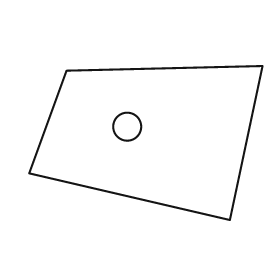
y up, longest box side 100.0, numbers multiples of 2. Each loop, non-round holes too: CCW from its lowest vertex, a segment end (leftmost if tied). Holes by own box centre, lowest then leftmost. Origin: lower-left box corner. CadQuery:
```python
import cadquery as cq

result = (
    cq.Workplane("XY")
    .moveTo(86.0, 0.0)
    .lineTo(100.0, 66.0)
    .lineTo(16.0, 64.0)
    .lineTo(0.0, 20.0)
    .close()
    .moveTo(42.0, 40.0)
    .circle(6.0)
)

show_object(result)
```